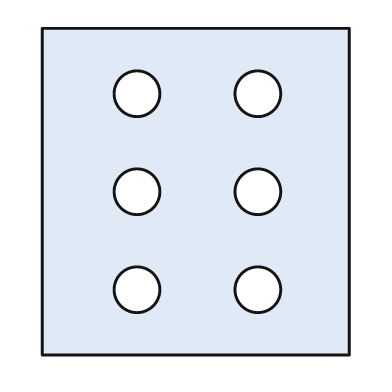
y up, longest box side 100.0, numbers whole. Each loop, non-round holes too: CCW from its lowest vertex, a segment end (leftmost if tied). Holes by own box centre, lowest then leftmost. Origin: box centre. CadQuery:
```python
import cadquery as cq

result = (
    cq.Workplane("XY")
    .moveTo(-47.0, -50.0)
    .lineTo(47.0, -50.0)
    .lineTo(47.0, 50.0)
    .lineTo(-47.0, 50.0)
    .close()
    .moveTo(-18.0, -30.0)
    .circle(7.0)
    .moveTo(19.0, -30.0)
    .circle(7.0)
    .moveTo(-18.0, 0.0)
    .circle(7.0)
    .moveTo(19.0, 0.0)
    .circle(7.0)
    .moveTo(-18.0, 30.0)
    .circle(7.0)
    .moveTo(19.0, 30.0)
    .circle(7.0)
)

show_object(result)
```